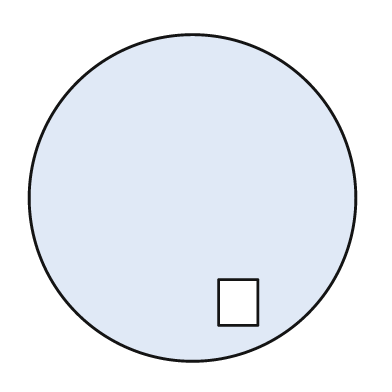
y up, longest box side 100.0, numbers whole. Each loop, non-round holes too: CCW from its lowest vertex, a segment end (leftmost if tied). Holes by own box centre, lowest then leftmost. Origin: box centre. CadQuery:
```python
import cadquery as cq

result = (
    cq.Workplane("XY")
    .moveTo(0.0, 0.0)
    .circle(50.0)
    .moveTo(8.0, -39.0)
    .lineTo(20.0, -39.0)
    .lineTo(20.0, -25.0)
    .lineTo(8.0, -25.0)
    .close()
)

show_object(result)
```